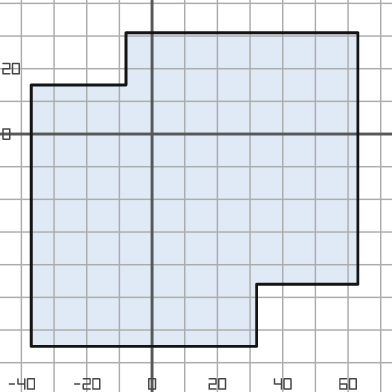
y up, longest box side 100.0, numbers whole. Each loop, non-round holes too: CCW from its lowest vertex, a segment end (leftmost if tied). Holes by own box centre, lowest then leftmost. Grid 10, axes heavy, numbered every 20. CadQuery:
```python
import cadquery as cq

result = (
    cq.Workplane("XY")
    .moveTo(-37.0, -65.0)
    .lineTo(32.0, -65.0)
    .lineTo(32.0, -46.0)
    .lineTo(63.0, -46.0)
    .lineTo(63.0, 31.0)
    .lineTo(-8.0, 31.0)
    .lineTo(-8.0, 15.0)
    .lineTo(-37.0, 15.0)
    .close()
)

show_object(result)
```